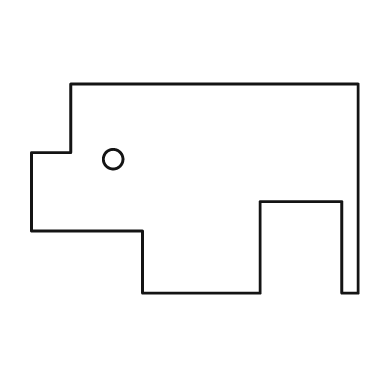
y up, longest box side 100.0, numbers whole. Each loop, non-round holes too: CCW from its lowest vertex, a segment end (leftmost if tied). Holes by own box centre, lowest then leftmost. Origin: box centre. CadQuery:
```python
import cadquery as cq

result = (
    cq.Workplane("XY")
    .moveTo(-16.0, -32.0)
    .lineTo(20.0, -32.0)
    .lineTo(20.0, -4.0)
    .lineTo(45.0, -4.0)
    .lineTo(45.0, -32.0)
    .lineTo(50.0, -32.0)
    .lineTo(50.0, 32.0)
    .lineTo(-38.0, 32.0)
    .lineTo(-38.0, 11.0)
    .lineTo(-50.0, 11.0)
    .lineTo(-50.0, -13.0)
    .lineTo(-16.0, -13.0)
    .close()
    .moveTo(-25.0, 9.0)
    .circle(3.0)
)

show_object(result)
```